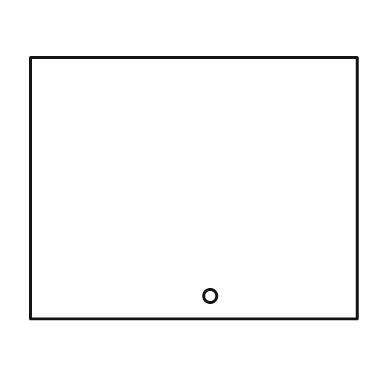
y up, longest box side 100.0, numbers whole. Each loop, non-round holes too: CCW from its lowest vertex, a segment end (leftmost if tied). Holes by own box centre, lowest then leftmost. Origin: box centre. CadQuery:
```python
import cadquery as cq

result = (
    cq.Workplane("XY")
    .moveTo(-50.0, -40.0)
    .lineTo(50.0, -40.0)
    .lineTo(50.0, 40.0)
    .lineTo(-50.0, 40.0)
    .close()
    .moveTo(5.0, -33.0)
    .circle(2.0)
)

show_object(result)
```